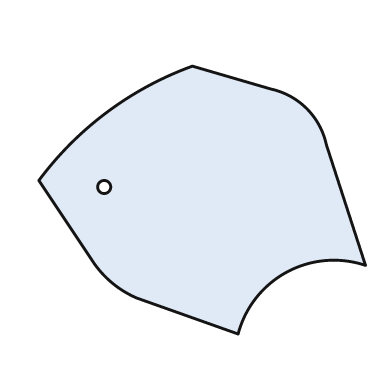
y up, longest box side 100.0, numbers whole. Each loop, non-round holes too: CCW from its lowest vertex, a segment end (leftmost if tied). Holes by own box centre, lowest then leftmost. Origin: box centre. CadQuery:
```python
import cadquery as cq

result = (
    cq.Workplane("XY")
    .moveTo(11.0, -41.0)
    .threePointArc((26.0, -22.0), (50.0, -20.0))
    .lineTo(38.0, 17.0)
    .threePointArc((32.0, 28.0), (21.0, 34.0))
    .lineTo(-3.0, 41.0)
    .threePointArc((-29.0, 27.0), (-50.0, 6.0))
    .lineTo(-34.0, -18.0)
    .threePointArc((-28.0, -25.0), (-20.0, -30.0))
    .close()
    .moveTo(-30.0, 4.0)
    .circle(2.0)
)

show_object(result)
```